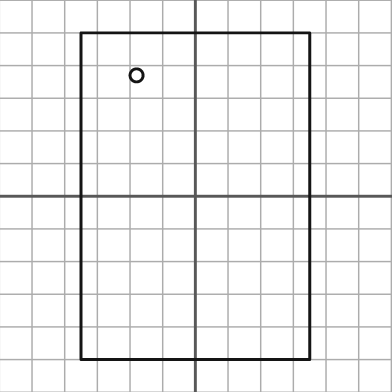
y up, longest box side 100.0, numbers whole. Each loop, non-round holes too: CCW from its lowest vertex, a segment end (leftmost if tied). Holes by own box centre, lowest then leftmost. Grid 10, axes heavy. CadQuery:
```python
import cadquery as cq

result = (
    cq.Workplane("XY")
    .moveTo(-35.0, -50.0)
    .lineTo(35.0, -50.0)
    .lineTo(35.0, 50.0)
    .lineTo(-35.0, 50.0)
    .close()
    .moveTo(-18.0, 37.0)
    .circle(2.0)
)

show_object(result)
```